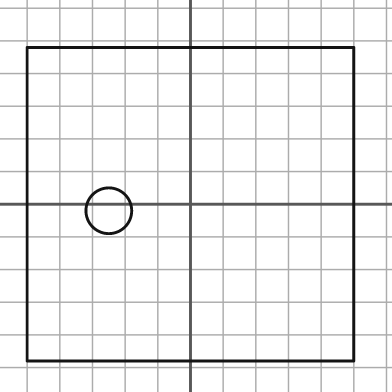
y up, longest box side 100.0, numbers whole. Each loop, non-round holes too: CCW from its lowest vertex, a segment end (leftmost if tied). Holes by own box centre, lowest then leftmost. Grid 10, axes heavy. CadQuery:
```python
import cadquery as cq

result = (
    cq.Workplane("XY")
    .moveTo(-50.0, -48.0)
    .lineTo(50.0, -48.0)
    .lineTo(50.0, 48.0)
    .lineTo(-50.0, 48.0)
    .close()
    .moveTo(-25.0, -2.0)
    .circle(7.0)
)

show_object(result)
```